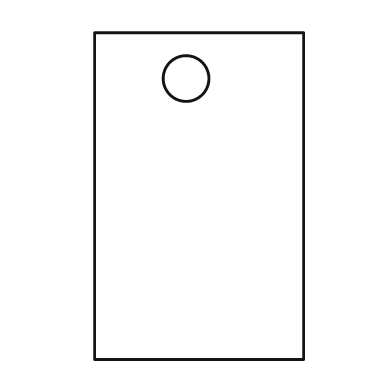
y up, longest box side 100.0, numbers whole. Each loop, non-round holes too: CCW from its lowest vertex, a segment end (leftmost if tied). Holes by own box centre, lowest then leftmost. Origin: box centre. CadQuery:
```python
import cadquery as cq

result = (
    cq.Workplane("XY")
    .moveTo(-32.0, -50.0)
    .lineTo(32.0, -50.0)
    .lineTo(32.0, 50.0)
    .lineTo(-32.0, 50.0)
    .close()
    .moveTo(-4.0, 36.0)
    .circle(7.0)
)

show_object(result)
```